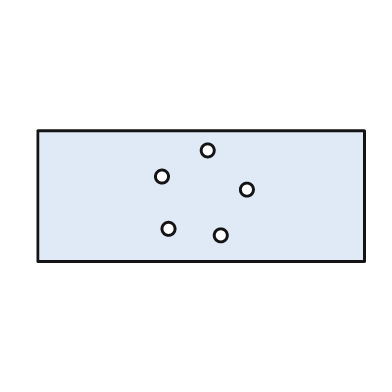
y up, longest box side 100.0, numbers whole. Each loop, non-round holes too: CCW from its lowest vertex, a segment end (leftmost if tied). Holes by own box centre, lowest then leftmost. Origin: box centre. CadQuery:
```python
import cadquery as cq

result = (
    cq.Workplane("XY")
    .moveTo(-50.0, -20.0)
    .lineTo(50.0, -20.0)
    .lineTo(50.0, 20.0)
    .lineTo(-50.0, 20.0)
    .close()
    .moveTo(6.0, -12.0)
    .circle(2.0)
    .moveTo(-10.0, -10.0)
    .circle(2.0)
    .moveTo(14.0, 2.0)
    .circle(2.0)
    .moveTo(-12.0, 6.0)
    .circle(2.0)
    .moveTo(2.0, 14.0)
    .circle(2.0)
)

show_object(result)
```